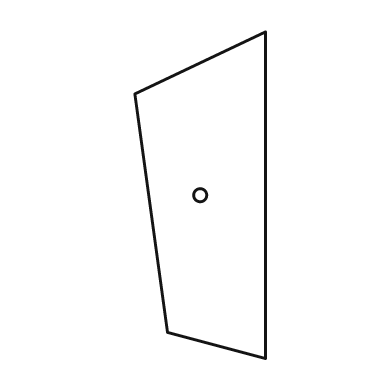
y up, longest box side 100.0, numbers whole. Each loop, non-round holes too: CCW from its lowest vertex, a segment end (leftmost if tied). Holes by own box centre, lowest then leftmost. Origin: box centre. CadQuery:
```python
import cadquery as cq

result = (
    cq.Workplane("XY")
    .moveTo(20.0, -50.0)
    .lineTo(20.0, 50.0)
    .lineTo(-20.0, 31.0)
    .lineTo(-10.0, -42.0)
    .close()
    .moveTo(0.0, 0.0)
    .circle(2.0)
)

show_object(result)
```